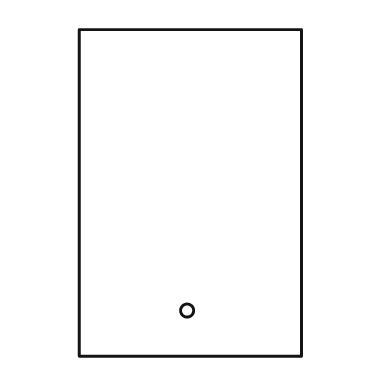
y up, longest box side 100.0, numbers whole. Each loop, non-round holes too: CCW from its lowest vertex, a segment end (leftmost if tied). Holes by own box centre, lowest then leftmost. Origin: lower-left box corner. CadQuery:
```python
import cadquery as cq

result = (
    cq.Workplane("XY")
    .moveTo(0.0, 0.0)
    .lineTo(68.0, 0.0)
    .lineTo(68.0, 100.0)
    .lineTo(0.0, 100.0)
    .close()
    .moveTo(33.0, 14.0)
    .circle(2.0)
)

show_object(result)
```